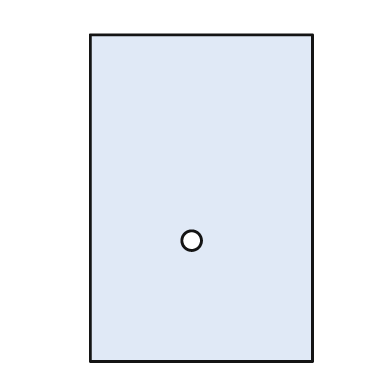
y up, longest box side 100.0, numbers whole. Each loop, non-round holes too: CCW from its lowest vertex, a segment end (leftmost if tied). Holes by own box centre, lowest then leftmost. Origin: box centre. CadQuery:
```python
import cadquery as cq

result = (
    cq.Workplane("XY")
    .moveTo(-34.0, -50.0)
    .lineTo(34.0, -50.0)
    .lineTo(34.0, 50.0)
    .lineTo(-34.0, 50.0)
    .close()
    .moveTo(-3.0, -13.0)
    .circle(3.0)
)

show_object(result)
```